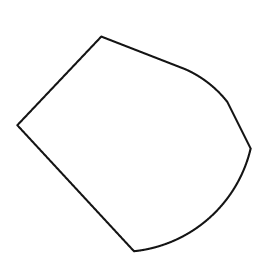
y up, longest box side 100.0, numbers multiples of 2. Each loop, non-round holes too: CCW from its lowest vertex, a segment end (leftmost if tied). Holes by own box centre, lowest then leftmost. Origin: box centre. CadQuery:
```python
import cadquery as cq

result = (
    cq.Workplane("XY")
    .moveTo(0.0, -46.0)
    .threePointArc((32.0, -32.0), (50.0, -2.0))
    .lineTo(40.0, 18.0)
    .threePointArc((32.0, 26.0), (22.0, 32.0))
    .lineTo(-14.0, 46.0)
    .lineTo(-50.0, 8.0)
    .close()
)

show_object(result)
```